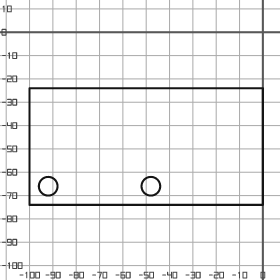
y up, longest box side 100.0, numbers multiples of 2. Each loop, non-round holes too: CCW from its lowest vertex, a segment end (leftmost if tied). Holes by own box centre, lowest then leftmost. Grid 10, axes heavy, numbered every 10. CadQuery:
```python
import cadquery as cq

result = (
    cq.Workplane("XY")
    .moveTo(-100.0, -74.0)
    .lineTo(0.0, -74.0)
    .lineTo(0.0, -24.0)
    .lineTo(-100.0, -24.0)
    .close()
    .moveTo(-92.0, -66.0)
    .circle(4.0)
    .moveTo(-48.0, -66.0)
    .circle(4.0)
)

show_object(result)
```